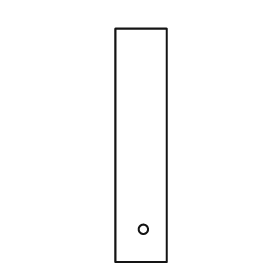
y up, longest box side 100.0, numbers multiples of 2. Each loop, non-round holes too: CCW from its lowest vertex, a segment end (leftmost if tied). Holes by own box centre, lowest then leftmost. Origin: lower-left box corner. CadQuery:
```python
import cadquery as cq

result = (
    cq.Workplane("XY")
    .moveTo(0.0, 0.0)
    .lineTo(22.0, 0.0)
    .lineTo(22.0, 100.0)
    .lineTo(0.0, 100.0)
    .close()
    .moveTo(12.0, 14.0)
    .circle(2.0)
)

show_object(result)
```